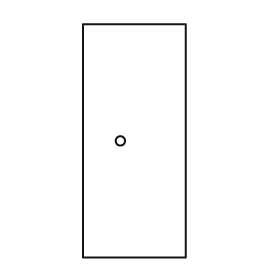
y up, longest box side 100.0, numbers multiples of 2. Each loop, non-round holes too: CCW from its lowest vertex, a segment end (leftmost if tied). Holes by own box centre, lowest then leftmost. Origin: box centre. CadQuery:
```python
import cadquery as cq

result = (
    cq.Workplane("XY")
    .moveTo(-22.0, -50.0)
    .lineTo(22.0, -50.0)
    .lineTo(22.0, 50.0)
    .lineTo(-22.0, 50.0)
    .close()
    .moveTo(-6.0, 0.0)
    .circle(2.0)
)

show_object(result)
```